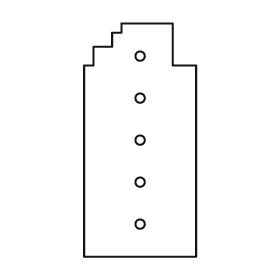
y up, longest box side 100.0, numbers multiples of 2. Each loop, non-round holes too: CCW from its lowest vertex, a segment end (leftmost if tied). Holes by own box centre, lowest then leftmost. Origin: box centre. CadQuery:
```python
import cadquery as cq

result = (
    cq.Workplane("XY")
    .moveTo(-24.0, -50.0)
    .lineTo(24.0, -50.0)
    .lineTo(24.0, 32.0)
    .lineTo(14.0, 32.0)
    .lineTo(14.0, 50.0)
    .lineTo(-8.0, 50.0)
    .lineTo(-8.0, 46.0)
    .lineTo(-12.0, 46.0)
    .lineTo(-12.0, 40.0)
    .lineTo(-20.0, 40.0)
    .lineTo(-20.0, 32.0)
    .lineTo(-24.0, 32.0)
    .close()
    .moveTo(0.0, -36.0)
    .circle(2.0)
    .moveTo(0.0, -18.0)
    .circle(2.0)
    .moveTo(0.0, 0.0)
    .circle(2.0)
    .moveTo(0.0, 18.0)
    .circle(2.0)
    .moveTo(0.0, 36.0)
    .circle(2.0)
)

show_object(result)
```